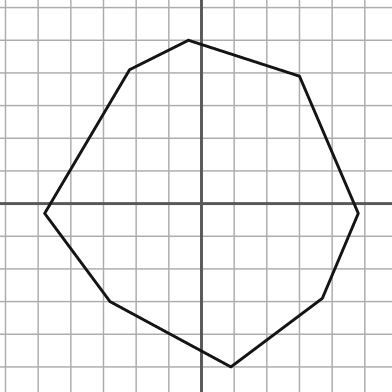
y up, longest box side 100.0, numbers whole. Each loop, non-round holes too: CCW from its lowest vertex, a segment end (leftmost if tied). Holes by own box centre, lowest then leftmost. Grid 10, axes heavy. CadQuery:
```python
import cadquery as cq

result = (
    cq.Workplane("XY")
    .moveTo(9.0, -50.0)
    .lineTo(37.0, -29.0)
    .lineTo(48.0, -3.0)
    .lineTo(30.0, 39.0)
    .lineTo(-4.0, 50.0)
    .lineTo(-22.0, 41.0)
    .lineTo(-48.0, -3.0)
    .lineTo(-28.0, -30.0)
    .close()
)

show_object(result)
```